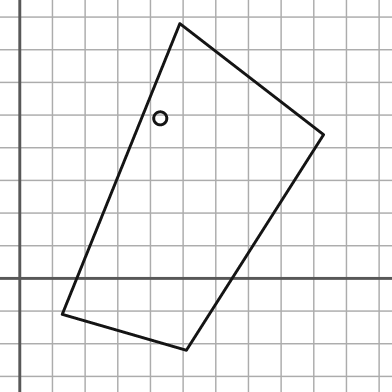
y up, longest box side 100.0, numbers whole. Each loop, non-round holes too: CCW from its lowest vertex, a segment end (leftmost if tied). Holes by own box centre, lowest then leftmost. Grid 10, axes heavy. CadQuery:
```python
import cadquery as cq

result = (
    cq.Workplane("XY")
    .moveTo(51.0, -22.0)
    .lineTo(93.0, 44.0)
    .lineTo(49.0, 78.0)
    .lineTo(13.0, -11.0)
    .close()
    .moveTo(43.0, 49.0)
    .circle(2.0)
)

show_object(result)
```